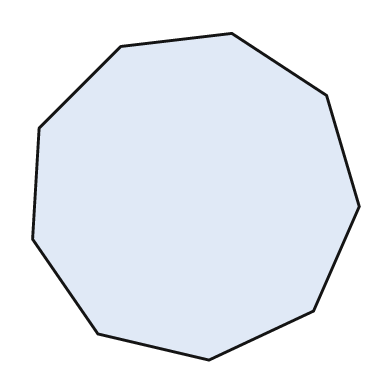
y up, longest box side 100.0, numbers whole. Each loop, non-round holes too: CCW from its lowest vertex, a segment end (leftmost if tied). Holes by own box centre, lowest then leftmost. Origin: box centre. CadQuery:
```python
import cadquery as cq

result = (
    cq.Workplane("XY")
    .moveTo(4.0, -50.0)
    .lineTo(36.0, -35.0)
    .lineTo(50.0, -3.0)
    .lineTo(40.0, 31.0)
    .lineTo(11.0, 50.0)
    .lineTo(-23.0, 46.0)
    .lineTo(-48.0, 21.0)
    .lineTo(-50.0, -13.0)
    .lineTo(-30.0, -42.0)
    .close()
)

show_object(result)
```